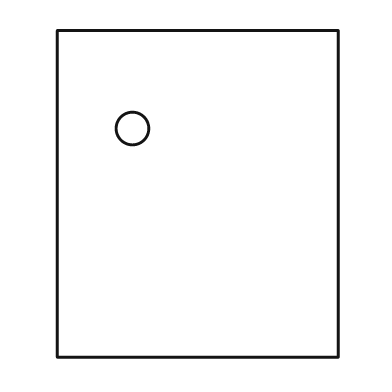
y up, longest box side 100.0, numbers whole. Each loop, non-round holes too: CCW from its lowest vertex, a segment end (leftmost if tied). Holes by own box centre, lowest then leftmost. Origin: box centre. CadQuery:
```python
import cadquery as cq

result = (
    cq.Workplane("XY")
    .moveTo(-43.0, -50.0)
    .lineTo(43.0, -50.0)
    .lineTo(43.0, 50.0)
    .lineTo(-43.0, 50.0)
    .close()
    .moveTo(-20.0, 20.0)
    .circle(5.0)
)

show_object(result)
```